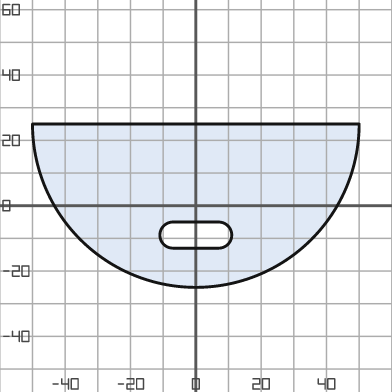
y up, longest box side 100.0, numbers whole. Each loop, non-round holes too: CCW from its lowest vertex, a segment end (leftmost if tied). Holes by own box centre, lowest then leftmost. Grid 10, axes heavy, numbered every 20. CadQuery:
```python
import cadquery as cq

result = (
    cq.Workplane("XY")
    .moveTo(-50.0, 25.0)
    .threePointArc((0.0, -25.0), (50.0, 25.0))
    .close()
    .moveTo(-7.0, -13.0)
    .lineTo(7.0, -13.0)
    .threePointArc((11.0, -9.0), (7.0, -5.0))
    .lineTo(-7.0, -5.0)
    .threePointArc((-11.0, -9.0), (-7.0, -13.0))
    .close()
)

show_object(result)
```